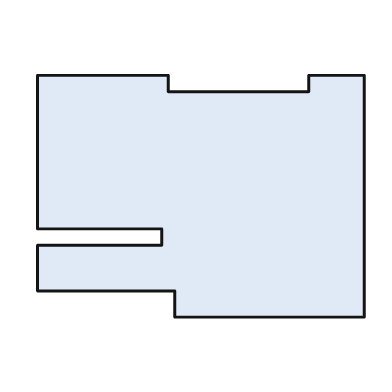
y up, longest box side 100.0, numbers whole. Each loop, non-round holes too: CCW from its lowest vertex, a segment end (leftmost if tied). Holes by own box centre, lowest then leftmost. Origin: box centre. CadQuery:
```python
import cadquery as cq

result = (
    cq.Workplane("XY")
    .moveTo(-8.0, -37.0)
    .lineTo(50.0, -37.0)
    .lineTo(50.0, 37.0)
    .lineTo(33.0, 37.0)
    .lineTo(33.0, 32.0)
    .lineTo(-10.0, 32.0)
    .lineTo(-10.0, 37.0)
    .lineTo(-50.0, 37.0)
    .lineTo(-50.0, -10.0)
    .lineTo(-12.0, -10.0)
    .lineTo(-12.0, -15.0)
    .lineTo(-50.0, -15.0)
    .lineTo(-50.0, -29.0)
    .lineTo(-8.0, -29.0)
    .close()
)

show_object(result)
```